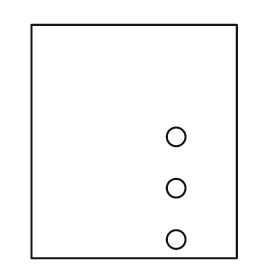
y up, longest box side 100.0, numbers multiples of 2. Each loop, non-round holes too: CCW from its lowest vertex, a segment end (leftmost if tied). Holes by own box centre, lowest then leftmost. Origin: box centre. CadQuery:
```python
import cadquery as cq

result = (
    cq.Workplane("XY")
    .moveTo(-44.0, -50.0)
    .lineTo(44.0, -50.0)
    .lineTo(44.0, 50.0)
    .lineTo(-44.0, 50.0)
    .close()
    .moveTo(18.0, -42.0)
    .circle(4.0)
    .moveTo(18.0, -20.0)
    .circle(4.0)
    .moveTo(18.0, 2.0)
    .circle(4.0)
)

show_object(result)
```